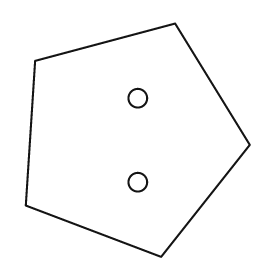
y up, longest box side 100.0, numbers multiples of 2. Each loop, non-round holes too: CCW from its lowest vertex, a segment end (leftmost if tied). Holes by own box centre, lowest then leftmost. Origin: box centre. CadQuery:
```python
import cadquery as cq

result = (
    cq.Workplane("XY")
    .moveTo(10.0, -50.0)
    .lineTo(48.0, -2.0)
    .lineTo(16.0, 50.0)
    .lineTo(-44.0, 34.0)
    .lineTo(-48.0, -28.0)
    .close()
    .moveTo(0.0, -18.0)
    .circle(4.0)
    .moveTo(0.0, 18.0)
    .circle(4.0)
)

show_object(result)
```